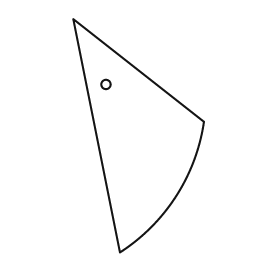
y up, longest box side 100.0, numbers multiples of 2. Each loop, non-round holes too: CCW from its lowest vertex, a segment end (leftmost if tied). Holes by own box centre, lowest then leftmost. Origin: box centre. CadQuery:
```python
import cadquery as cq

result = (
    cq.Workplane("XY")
    .moveTo(-8.0, -50.0)
    .threePointArc((16.0, -26.0), (28.0, 6.0))
    .lineTo(-28.0, 50.0)
    .close()
    .moveTo(-14.0, 22.0)
    .circle(2.0)
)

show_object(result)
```